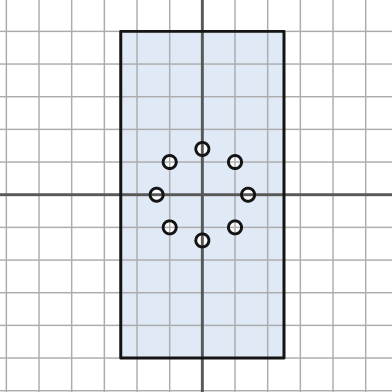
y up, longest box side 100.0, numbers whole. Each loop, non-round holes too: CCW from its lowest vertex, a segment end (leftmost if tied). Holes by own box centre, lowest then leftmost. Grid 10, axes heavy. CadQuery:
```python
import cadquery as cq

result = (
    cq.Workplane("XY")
    .moveTo(-25.0, -50.0)
    .lineTo(25.0, -50.0)
    .lineTo(25.0, 50.0)
    .lineTo(-25.0, 50.0)
    .close()
    .moveTo(0.0, -14.0)
    .circle(2.0)
    .moveTo(-10.0, -10.0)
    .circle(2.0)
    .moveTo(10.0, -10.0)
    .circle(2.0)
    .moveTo(-14.0, 0.0)
    .circle(2.0)
    .moveTo(14.0, 0.0)
    .circle(2.0)
    .moveTo(-10.0, 10.0)
    .circle(2.0)
    .moveTo(10.0, 10.0)
    .circle(2.0)
    .moveTo(0.0, 14.0)
    .circle(2.0)
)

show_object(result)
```